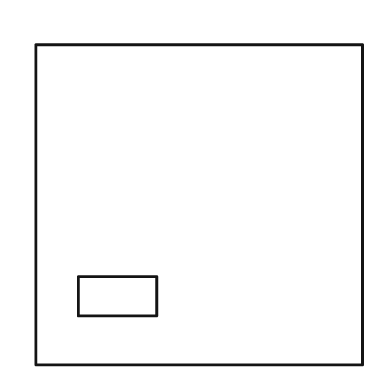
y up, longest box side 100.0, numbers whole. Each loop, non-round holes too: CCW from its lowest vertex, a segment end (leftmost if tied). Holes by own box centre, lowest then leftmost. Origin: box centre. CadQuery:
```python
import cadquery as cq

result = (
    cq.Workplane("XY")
    .moveTo(-50.0, -49.0)
    .lineTo(50.0, -49.0)
    .lineTo(50.0, 49.0)
    .lineTo(-50.0, 49.0)
    .close()
    .moveTo(-37.0, -34.0)
    .lineTo(-13.0, -34.0)
    .lineTo(-13.0, -22.0)
    .lineTo(-37.0, -22.0)
    .close()
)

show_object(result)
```